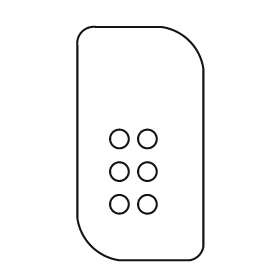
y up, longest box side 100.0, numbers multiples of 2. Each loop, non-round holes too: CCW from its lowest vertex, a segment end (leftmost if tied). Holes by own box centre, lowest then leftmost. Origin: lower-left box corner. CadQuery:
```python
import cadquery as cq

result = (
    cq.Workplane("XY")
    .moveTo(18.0, 0.0)
    .lineTo(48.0, 0.0)
    .threePointArc((52.0, 2.0), (54.0, 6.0))
    .lineTo(54.0, 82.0)
    .threePointArc((48.0, 94.0), (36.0, 100.0))
    .lineTo(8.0, 100.0)
    .threePointArc((2.0, 98.0), (0.0, 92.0))
    .lineTo(0.0, 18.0)
    .threePointArc((6.0, 6.0), (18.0, 0.0))
    .close()
    .moveTo(18.0, 24.0)
    .circle(4.0)
    .moveTo(30.0, 24.0)
    .circle(4.0)
    .moveTo(18.0, 38.0)
    .circle(4.0)
    .moveTo(30.0, 38.0)
    .circle(4.0)
    .moveTo(18.0, 52.0)
    .circle(4.0)
    .moveTo(30.0, 52.0)
    .circle(4.0)
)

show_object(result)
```